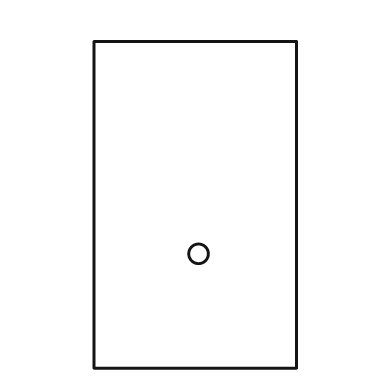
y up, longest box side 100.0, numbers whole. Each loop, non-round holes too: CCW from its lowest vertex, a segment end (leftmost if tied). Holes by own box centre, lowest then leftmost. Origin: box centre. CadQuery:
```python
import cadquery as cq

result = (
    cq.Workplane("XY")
    .moveTo(-31.0, -50.0)
    .lineTo(31.0, -50.0)
    .lineTo(31.0, 50.0)
    .lineTo(-31.0, 50.0)
    .close()
    .moveTo(1.0, -15.0)
    .circle(3.0)
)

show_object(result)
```